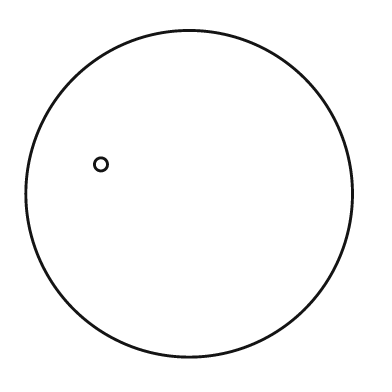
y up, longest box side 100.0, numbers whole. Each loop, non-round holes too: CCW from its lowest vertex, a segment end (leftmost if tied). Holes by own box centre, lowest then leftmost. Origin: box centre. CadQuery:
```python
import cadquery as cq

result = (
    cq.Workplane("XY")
    .moveTo(0.0, 0.0)
    .circle(50.0)
    .moveTo(-27.0, 9.0)
    .circle(2.0)
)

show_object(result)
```